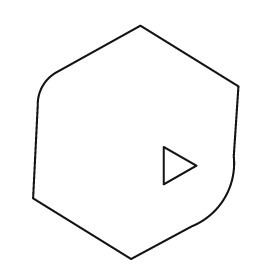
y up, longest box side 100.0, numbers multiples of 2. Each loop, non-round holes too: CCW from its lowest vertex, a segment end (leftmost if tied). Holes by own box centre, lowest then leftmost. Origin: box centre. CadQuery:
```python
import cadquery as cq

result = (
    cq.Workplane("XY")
    .moveTo(-2.0, -50.0)
    .lineTo(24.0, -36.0)
    .threePointArc((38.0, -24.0), (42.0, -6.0))
    .lineTo(44.0, 24.0)
    .lineTo(2.0, 50.0)
    .lineTo(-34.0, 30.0)
    .threePointArc((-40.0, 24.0), (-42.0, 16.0))
    .lineTo(-44.0, -24.0)
    .close()
    .moveTo(12.0, -18.0)
    .lineTo(26.0, -10.0)
    .lineTo(12.0, -2.0)
    .close()
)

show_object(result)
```